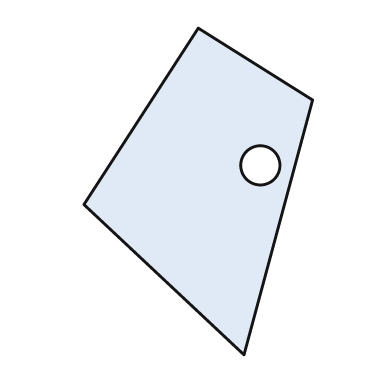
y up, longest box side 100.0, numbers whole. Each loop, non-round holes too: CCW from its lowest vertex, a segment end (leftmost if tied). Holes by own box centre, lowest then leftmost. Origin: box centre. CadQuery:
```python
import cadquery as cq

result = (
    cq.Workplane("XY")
    .moveTo(14.0, -50.0)
    .lineTo(35.0, 28.0)
    .lineTo(0.0, 50.0)
    .lineTo(-35.0, -4.0)
    .close()
    .moveTo(19.0, 8.0)
    .circle(6.0)
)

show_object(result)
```